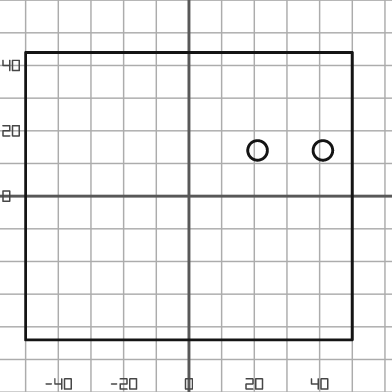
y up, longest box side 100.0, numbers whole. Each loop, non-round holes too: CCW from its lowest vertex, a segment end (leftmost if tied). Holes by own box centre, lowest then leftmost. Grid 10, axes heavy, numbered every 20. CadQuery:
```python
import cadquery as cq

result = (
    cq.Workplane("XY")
    .moveTo(-50.0, -44.0)
    .lineTo(50.0, -44.0)
    .lineTo(50.0, 44.0)
    .lineTo(-50.0, 44.0)
    .close()
    .moveTo(21.0, 14.0)
    .circle(3.0)
    .moveTo(41.0, 14.0)
    .circle(3.0)
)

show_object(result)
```